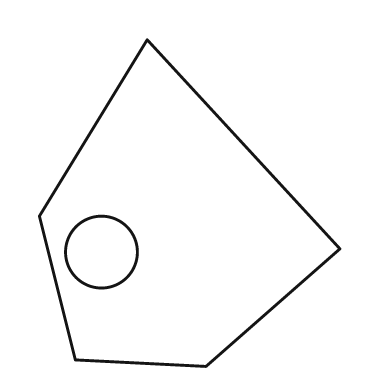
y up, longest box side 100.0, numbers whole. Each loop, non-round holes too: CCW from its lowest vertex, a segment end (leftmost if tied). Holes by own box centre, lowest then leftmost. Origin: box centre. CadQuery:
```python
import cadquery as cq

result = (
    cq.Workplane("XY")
    .moveTo(5.0, -50.0)
    .lineTo(46.0, -14.0)
    .lineTo(-13.0, 50.0)
    .lineTo(-46.0, -4.0)
    .lineTo(-35.0, -48.0)
    .close()
    .moveTo(-27.0, -15.0)
    .circle(11.0)
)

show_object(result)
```